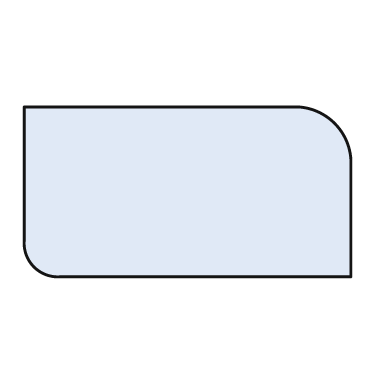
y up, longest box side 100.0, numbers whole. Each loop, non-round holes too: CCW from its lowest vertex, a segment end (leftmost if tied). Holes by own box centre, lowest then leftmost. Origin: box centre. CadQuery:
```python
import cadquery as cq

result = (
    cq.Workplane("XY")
    .moveTo(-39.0, -26.0)
    .lineTo(50.0, -26.0)
    .lineTo(50.0, 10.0)
    .threePointArc((45.0, 21.0), (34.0, 26.0))
    .lineTo(-50.0, 26.0)
    .lineTo(-50.0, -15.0)
    .threePointArc((-47.0, -23.0), (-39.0, -26.0))
    .close()
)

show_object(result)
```